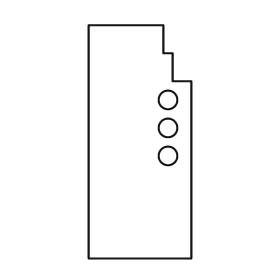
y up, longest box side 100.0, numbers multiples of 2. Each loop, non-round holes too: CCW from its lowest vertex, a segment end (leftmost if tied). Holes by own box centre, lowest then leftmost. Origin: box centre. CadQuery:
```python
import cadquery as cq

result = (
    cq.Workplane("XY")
    .moveTo(-22.0, -50.0)
    .lineTo(22.0, -50.0)
    .lineTo(22.0, 26.0)
    .lineTo(14.0, 26.0)
    .lineTo(14.0, 38.0)
    .lineTo(10.0, 38.0)
    .lineTo(10.0, 50.0)
    .lineTo(-22.0, 50.0)
    .close()
    .moveTo(12.0, -6.0)
    .circle(4.0)
    .moveTo(12.0, 6.0)
    .circle(4.0)
    .moveTo(12.0, 18.0)
    .circle(4.0)
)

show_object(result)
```